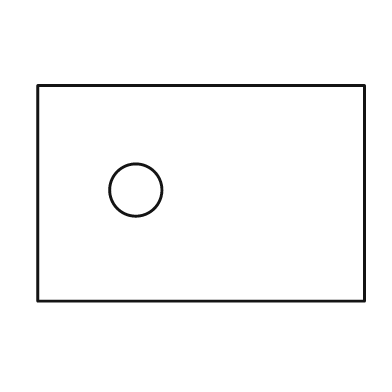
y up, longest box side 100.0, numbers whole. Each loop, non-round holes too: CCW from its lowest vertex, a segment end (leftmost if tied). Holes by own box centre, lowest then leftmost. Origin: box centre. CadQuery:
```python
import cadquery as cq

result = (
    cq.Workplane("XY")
    .moveTo(-50.0, -33.0)
    .lineTo(50.0, -33.0)
    .lineTo(50.0, 33.0)
    .lineTo(-50.0, 33.0)
    .close()
    .moveTo(-20.0, 1.0)
    .circle(8.0)
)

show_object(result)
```